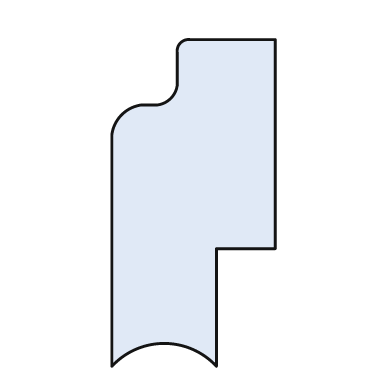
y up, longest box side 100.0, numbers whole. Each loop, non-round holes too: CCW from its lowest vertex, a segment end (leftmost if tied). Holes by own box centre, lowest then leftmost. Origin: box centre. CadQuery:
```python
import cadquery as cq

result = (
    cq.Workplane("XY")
    .moveTo(-25.0, -50.0)
    .threePointArc((-9.0, -43.0), (7.0, -50.0))
    .lineTo(7.0, -14.0)
    .lineTo(25.0, -14.0)
    .lineTo(25.0, 50.0)
    .lineTo(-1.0, 50.0)
    .threePointArc((-4.0, 49.0), (-5.0, 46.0))
    .lineTo(-5.0, 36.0)
    .threePointArc((-7.0, 32.0), (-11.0, 30.0))
    .lineTo(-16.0, 30.0)
    .threePointArc((-22.0, 27.0), (-25.0, 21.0))
    .close()
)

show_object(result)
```